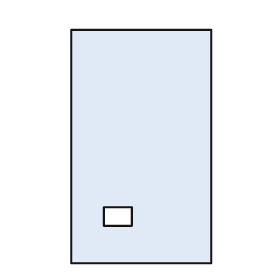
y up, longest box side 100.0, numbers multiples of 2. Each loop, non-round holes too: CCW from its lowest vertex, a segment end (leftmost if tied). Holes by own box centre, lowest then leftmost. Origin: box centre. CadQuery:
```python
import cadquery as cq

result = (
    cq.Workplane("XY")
    .moveTo(-30.0, -50.0)
    .lineTo(30.0, -50.0)
    .lineTo(30.0, 50.0)
    .lineTo(-30.0, 50.0)
    .close()
    .moveTo(-16.0, -34.0)
    .lineTo(-4.0, -34.0)
    .lineTo(-4.0, -26.0)
    .lineTo(-16.0, -26.0)
    .close()
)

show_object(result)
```